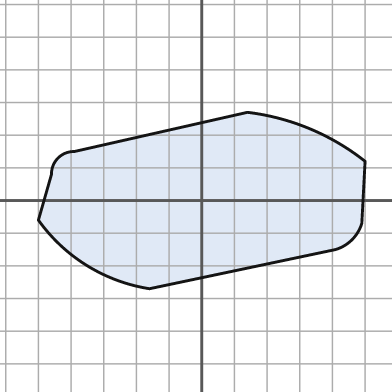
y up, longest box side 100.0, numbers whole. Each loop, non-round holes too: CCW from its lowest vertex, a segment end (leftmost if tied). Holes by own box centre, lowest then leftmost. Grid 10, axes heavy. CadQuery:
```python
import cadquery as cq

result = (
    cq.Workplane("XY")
    .moveTo(-16.0, -27.0)
    .lineTo(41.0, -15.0)
    .threePointArc((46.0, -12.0), (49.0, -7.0))
    .lineTo(50.0, 12.0)
    .threePointArc((33.0, 22.0), (14.0, 27.0))
    .lineTo(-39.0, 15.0)
    .threePointArc((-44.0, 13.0), (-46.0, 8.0))
    .lineTo(-50.0, -6.0)
    .threePointArc((-35.0, -20.0), (-16.0, -27.0))
    .close()
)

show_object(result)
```